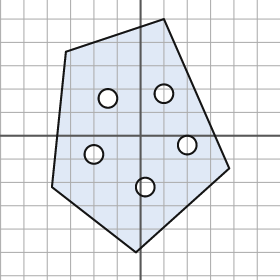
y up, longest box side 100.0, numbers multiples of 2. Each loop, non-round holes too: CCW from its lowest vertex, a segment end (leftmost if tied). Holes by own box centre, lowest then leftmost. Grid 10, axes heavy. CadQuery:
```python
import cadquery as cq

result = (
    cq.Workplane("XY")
    .moveTo(-2.0, -50.0)
    .lineTo(38.0, -14.0)
    .lineTo(10.0, 50.0)
    .lineTo(-32.0, 36.0)
    .lineTo(-38.0, -22.0)
    .close()
    .moveTo(2.0, -22.0)
    .circle(4.0)
    .moveTo(-20.0, -8.0)
    .circle(4.0)
    .moveTo(20.0, -4.0)
    .circle(4.0)
    .moveTo(-14.0, 16.0)
    .circle(4.0)
    .moveTo(10.0, 18.0)
    .circle(4.0)
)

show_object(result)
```